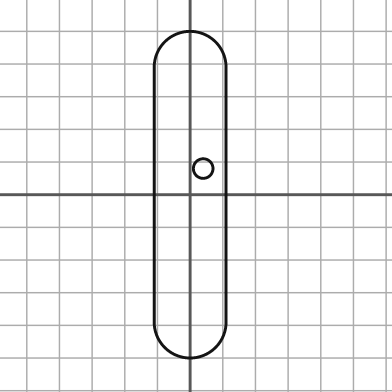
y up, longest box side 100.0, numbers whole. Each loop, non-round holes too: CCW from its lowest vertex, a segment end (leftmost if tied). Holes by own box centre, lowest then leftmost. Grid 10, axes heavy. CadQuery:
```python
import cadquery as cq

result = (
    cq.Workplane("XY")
    .moveTo(-11.0, -39.0)
    .threePointArc((0.0, -50.0), (11.0, -39.0))
    .lineTo(11.0, 39.0)
    .threePointArc((0.0, 50.0), (-11.0, 39.0))
    .close()
    .moveTo(4.0, 8.0)
    .circle(3.0)
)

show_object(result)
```